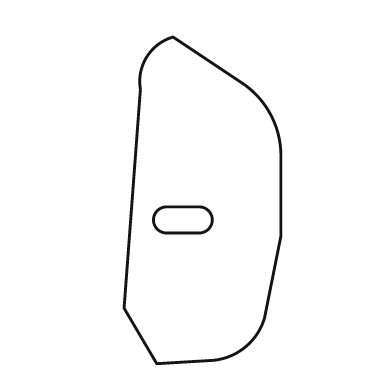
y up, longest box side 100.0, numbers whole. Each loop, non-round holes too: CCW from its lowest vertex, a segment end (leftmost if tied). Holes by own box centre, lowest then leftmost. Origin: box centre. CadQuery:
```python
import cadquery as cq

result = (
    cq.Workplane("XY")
    .moveTo(-14.0, -50.0)
    .lineTo(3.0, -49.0)
    .threePointArc((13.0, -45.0), (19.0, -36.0))
    .lineTo(24.0, -11.0)
    .lineTo(24.0, 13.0)
    .threePointArc((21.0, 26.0), (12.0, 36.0))
    .lineTo(-9.0, 50.0)
    .threePointArc((-17.0, 44.0), (-19.0, 34.0))
    .lineTo(-24.0, -33.0)
    .close()
    .moveTo(-11.0, -10.0)
    .lineTo(-1.0, -10.0)
    .threePointArc((3.0, -6.0), (-1.0, -2.0))
    .lineTo(-11.0, -2.0)
    .threePointArc((-15.0, -6.0), (-11.0, -10.0))
    .close()
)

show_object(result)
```